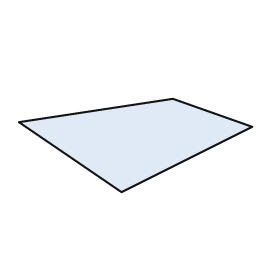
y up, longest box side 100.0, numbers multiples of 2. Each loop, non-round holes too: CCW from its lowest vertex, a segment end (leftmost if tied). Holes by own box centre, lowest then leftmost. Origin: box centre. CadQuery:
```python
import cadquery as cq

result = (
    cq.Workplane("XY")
    .moveTo(-6.0, -20.0)
    .lineTo(50.0, 8.0)
    .lineTo(16.0, 20.0)
    .lineTo(-50.0, 10.0)
    .close()
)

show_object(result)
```